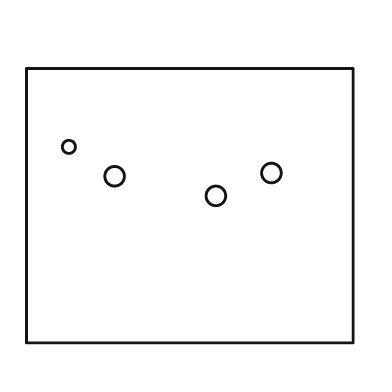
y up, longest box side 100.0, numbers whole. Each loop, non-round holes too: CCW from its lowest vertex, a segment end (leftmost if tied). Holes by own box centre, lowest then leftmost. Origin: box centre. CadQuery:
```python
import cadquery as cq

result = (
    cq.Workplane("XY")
    .moveTo(-50.0, -42.0)
    .lineTo(50.0, -42.0)
    .lineTo(50.0, 42.0)
    .lineTo(-50.0, 42.0)
    .close()
    .moveTo(8.0, 3.0)
    .circle(3.0)
    .moveTo(-23.0, 9.0)
    .circle(3.0)
    .moveTo(25.0, 10.0)
    .circle(3.0)
    .moveTo(-37.0, 18.0)
    .circle(2.0)
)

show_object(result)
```